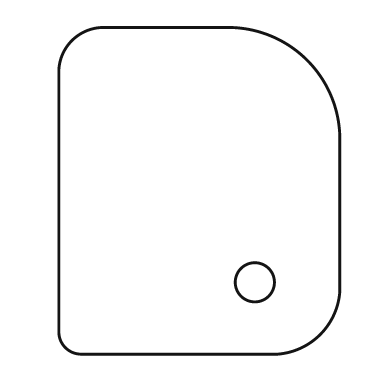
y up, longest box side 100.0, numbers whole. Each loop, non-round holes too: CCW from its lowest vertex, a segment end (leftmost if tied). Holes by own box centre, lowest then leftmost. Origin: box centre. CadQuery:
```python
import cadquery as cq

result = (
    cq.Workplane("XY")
    .moveTo(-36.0, -50.0)
    .lineTo(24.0, -50.0)
    .threePointArc((37.0, -44.0), (43.0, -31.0))
    .lineTo(43.0, 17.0)
    .threePointArc((33.0, 40.0), (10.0, 50.0))
    .lineTo(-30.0, 50.0)
    .threePointArc((-39.0, 46.0), (-43.0, 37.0))
    .lineTo(-43.0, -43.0)
    .threePointArc((-41.0, -48.0), (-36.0, -50.0))
    .close()
    .moveTo(17.0, -28.0)
    .circle(6.0)
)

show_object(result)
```